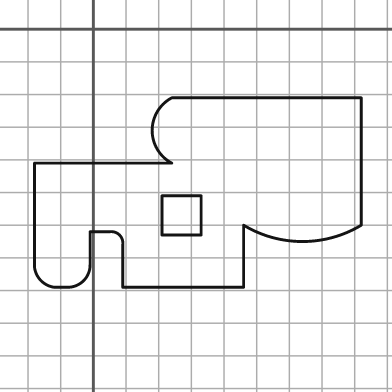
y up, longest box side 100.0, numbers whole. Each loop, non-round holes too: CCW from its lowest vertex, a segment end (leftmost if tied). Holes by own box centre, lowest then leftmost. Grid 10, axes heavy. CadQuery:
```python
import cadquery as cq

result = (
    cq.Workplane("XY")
    .moveTo(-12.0, -79.0)
    .lineTo(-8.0, -79.0)
    .threePointArc((-3.0, -77.0), (-1.0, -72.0))
    .lineTo(-1.0, -62.0)
    .lineTo(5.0, -62.0)
    .threePointArc((8.0, -63.0), (9.0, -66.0))
    .lineTo(9.0, -79.0)
    .lineTo(46.0, -79.0)
    .lineTo(46.0, -60.0)
    .threePointArc((64.0, -65.0), (82.0, -60.0))
    .lineTo(82.0, -21.0)
    .lineTo(24.0, -21.0)
    .threePointArc((18.0, -31.0), (24.0, -41.0))
    .lineTo(-18.0, -41.0)
    .lineTo(-18.0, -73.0)
    .threePointArc((-16.0, -77.0), (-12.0, -79.0))
    .close()
    .moveTo(21.0, -63.0)
    .lineTo(33.0, -63.0)
    .lineTo(33.0, -51.0)
    .lineTo(21.0, -51.0)
    .close()
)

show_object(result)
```